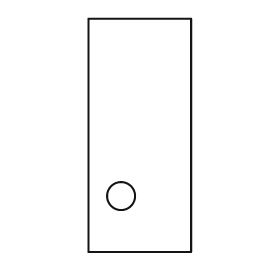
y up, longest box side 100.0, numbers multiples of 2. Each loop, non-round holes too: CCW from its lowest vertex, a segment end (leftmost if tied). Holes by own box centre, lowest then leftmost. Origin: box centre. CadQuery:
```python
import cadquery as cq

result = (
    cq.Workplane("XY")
    .moveTo(-22.0, -50.0)
    .lineTo(22.0, -50.0)
    .lineTo(22.0, 50.0)
    .lineTo(-22.0, 50.0)
    .close()
    .moveTo(-8.0, -26.0)
    .circle(6.0)
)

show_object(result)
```